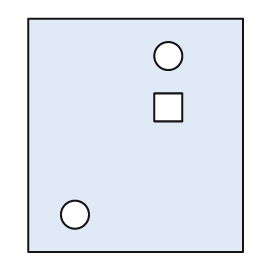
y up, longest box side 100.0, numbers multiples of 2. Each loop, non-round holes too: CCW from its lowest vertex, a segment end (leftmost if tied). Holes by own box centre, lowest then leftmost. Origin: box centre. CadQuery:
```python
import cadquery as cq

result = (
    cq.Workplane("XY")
    .moveTo(-46.0, -50.0)
    .lineTo(46.0, -50.0)
    .lineTo(46.0, 50.0)
    .lineTo(-46.0, 50.0)
    .close()
    .moveTo(-26.0, -34.0)
    .circle(6.0)
    .moveTo(8.0, 6.0)
    .lineTo(20.0, 6.0)
    .lineTo(20.0, 18.0)
    .lineTo(8.0, 18.0)
    .close()
    .moveTo(14.0, 34.0)
    .circle(6.0)
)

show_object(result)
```